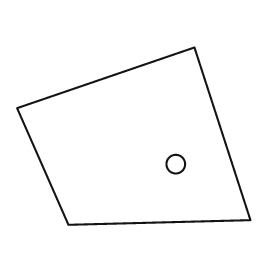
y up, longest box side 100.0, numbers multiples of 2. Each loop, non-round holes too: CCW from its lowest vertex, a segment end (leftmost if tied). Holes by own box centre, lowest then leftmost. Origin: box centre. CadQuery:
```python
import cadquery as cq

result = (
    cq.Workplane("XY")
    .moveTo(-28.0, -38.0)
    .lineTo(50.0, -36.0)
    .lineTo(26.0, 38.0)
    .lineTo(-50.0, 12.0)
    .close()
    .moveTo(18.0, -12.0)
    .circle(4.0)
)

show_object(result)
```